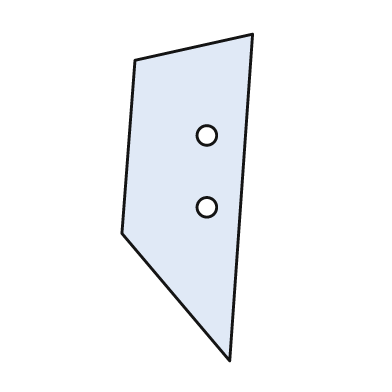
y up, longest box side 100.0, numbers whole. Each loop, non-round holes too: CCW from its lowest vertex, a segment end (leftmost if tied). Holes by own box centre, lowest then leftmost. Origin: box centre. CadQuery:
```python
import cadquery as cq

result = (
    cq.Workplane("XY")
    .moveTo(13.0, -50.0)
    .lineTo(20.0, 50.0)
    .lineTo(-16.0, 42.0)
    .lineTo(-20.0, -11.0)
    .close()
    .moveTo(6.0, -3.0)
    .circle(3.0)
    .moveTo(6.0, 19.0)
    .circle(3.0)
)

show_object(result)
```